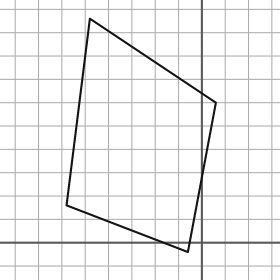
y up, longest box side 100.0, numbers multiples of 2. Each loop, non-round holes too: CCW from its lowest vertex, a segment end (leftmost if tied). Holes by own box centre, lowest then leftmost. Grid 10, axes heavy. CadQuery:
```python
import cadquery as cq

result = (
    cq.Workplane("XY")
    .moveTo(-6.0, -4.0)
    .lineTo(6.0, 60.0)
    .lineTo(-48.0, 96.0)
    .lineTo(-58.0, 16.0)
    .close()
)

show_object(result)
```